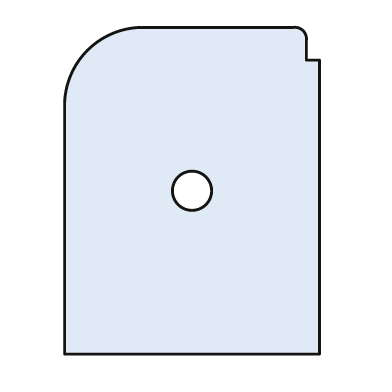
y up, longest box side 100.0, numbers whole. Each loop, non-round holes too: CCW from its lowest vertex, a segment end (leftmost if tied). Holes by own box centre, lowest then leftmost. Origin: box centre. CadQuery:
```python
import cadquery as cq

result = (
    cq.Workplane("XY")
    .moveTo(-39.0, -50.0)
    .lineTo(39.0, -50.0)
    .lineTo(39.0, 40.0)
    .lineTo(35.0, 40.0)
    .lineTo(35.0, 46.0)
    .threePointArc((34.0, 49.0), (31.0, 50.0))
    .lineTo(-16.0, 50.0)
    .threePointArc((-32.0, 43.0), (-39.0, 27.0))
    .close()
    .moveTo(0.0, 0.0)
    .circle(6.0)
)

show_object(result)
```